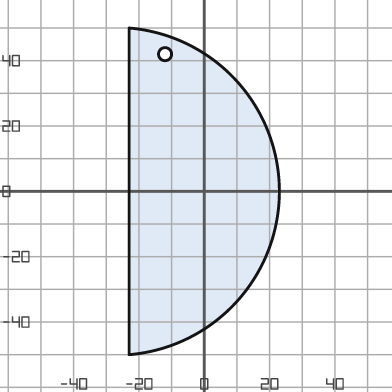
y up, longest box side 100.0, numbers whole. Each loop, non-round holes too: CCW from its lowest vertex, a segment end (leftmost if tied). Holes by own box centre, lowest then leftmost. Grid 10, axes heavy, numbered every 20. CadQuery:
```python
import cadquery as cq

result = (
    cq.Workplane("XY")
    .moveTo(-23.0, -50.0)
    .threePointArc((23.0, 0.0), (-23.0, 50.0))
    .close()
    .moveTo(-12.0, 42.0)
    .circle(2.0)
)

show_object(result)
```